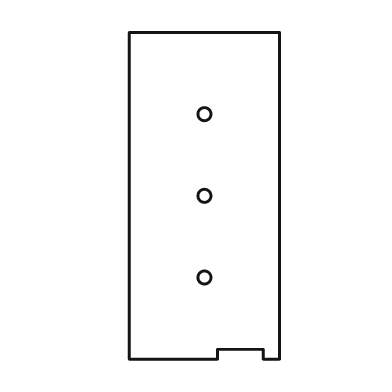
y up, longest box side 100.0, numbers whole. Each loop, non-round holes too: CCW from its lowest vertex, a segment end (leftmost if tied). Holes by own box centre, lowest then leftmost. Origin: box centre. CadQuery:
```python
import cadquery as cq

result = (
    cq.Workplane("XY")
    .moveTo(-23.0, -50.0)
    .lineTo(4.0, -50.0)
    .lineTo(4.0, -47.0)
    .lineTo(18.0, -47.0)
    .lineTo(18.0, -50.0)
    .lineTo(23.0, -50.0)
    .lineTo(23.0, 50.0)
    .lineTo(-23.0, 50.0)
    .close()
    .moveTo(0.0, -25.0)
    .circle(2.0)
    .moveTo(0.0, 0.0)
    .circle(2.0)
    .moveTo(0.0, 25.0)
    .circle(2.0)
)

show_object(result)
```